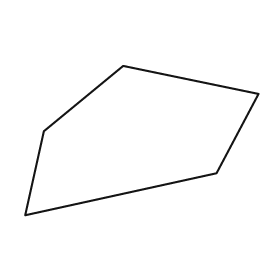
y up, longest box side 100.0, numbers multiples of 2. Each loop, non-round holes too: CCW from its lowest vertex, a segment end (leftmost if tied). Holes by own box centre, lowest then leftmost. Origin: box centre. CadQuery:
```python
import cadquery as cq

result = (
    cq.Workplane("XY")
    .moveTo(-50.0, -32.0)
    .lineTo(32.0, -14.0)
    .lineTo(50.0, 20.0)
    .lineTo(-8.0, 32.0)
    .lineTo(-42.0, 4.0)
    .close()
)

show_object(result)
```